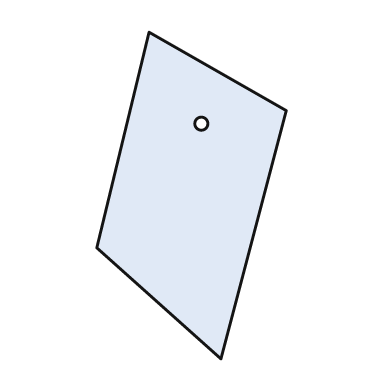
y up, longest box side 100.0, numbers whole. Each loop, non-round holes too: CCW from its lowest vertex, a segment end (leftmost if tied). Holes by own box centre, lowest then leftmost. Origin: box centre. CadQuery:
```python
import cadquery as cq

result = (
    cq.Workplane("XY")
    .moveTo(9.0, -50.0)
    .lineTo(29.0, 26.0)
    .lineTo(-13.0, 50.0)
    .lineTo(-29.0, -16.0)
    .close()
    .moveTo(3.0, 22.0)
    .circle(2.0)
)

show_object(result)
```